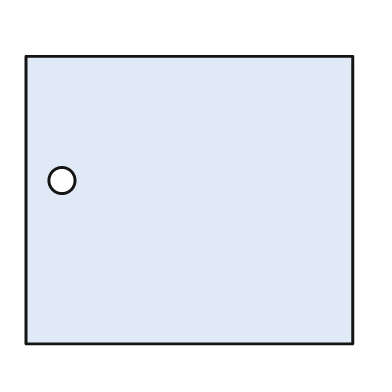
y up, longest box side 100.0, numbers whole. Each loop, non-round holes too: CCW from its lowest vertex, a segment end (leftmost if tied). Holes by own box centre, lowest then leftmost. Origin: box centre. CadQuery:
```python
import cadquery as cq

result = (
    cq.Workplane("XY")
    .moveTo(-50.0, -44.0)
    .lineTo(50.0, -44.0)
    .lineTo(50.0, 44.0)
    .lineTo(-50.0, 44.0)
    .close()
    .moveTo(-39.0, 6.0)
    .circle(4.0)
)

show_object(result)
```